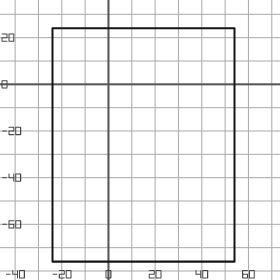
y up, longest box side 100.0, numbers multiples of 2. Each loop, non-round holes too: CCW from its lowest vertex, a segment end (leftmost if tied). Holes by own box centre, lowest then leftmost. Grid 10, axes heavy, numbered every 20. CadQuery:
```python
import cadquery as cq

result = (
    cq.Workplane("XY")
    .moveTo(-24.0, -76.0)
    .lineTo(54.0, -76.0)
    .lineTo(54.0, 24.0)
    .lineTo(-24.0, 24.0)
    .close()
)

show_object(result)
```